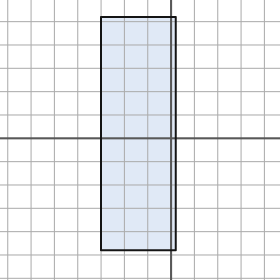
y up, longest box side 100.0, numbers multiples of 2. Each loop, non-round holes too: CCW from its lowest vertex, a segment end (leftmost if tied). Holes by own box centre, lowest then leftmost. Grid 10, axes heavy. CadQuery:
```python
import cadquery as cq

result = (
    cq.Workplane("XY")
    .moveTo(-30.0, -48.0)
    .lineTo(2.0, -48.0)
    .lineTo(2.0, 52.0)
    .lineTo(-30.0, 52.0)
    .close()
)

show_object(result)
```